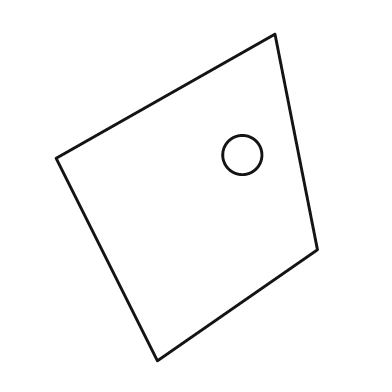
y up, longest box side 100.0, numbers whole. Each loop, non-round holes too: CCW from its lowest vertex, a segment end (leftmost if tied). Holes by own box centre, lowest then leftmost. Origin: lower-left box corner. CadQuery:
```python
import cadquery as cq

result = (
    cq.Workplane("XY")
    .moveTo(31.0, 0.0)
    .lineTo(80.0, 34.0)
    .lineTo(67.0, 100.0)
    .lineTo(0.0, 62.0)
    .close()
    .moveTo(57.0, 63.0)
    .circle(6.0)
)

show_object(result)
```